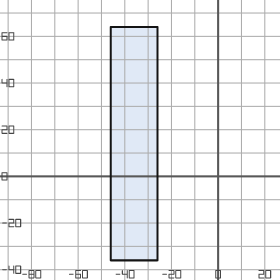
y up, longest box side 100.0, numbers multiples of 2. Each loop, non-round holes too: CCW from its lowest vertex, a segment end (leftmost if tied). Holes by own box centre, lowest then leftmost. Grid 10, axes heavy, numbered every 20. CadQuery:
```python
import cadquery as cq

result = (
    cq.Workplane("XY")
    .moveTo(-46.0, -36.0)
    .lineTo(-26.0, -36.0)
    .lineTo(-26.0, 64.0)
    .lineTo(-46.0, 64.0)
    .close()
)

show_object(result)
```